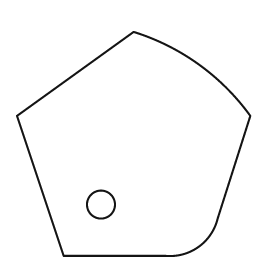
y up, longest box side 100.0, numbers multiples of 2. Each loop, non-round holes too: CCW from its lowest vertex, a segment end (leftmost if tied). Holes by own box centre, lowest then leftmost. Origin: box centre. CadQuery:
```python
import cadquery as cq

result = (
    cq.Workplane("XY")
    .moveTo(-30.0, -48.0)
    .lineTo(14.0, -48.0)
    .threePointArc((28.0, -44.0), (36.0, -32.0))
    .lineTo(50.0, 12.0)
    .threePointArc((28.0, 34.0), (0.0, 48.0))
    .lineTo(-50.0, 12.0)
    .close()
    .moveTo(-14.0, -26.0)
    .circle(6.0)
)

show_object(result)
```